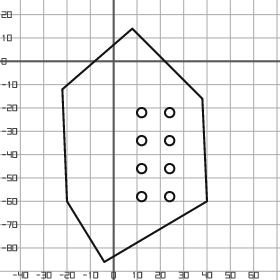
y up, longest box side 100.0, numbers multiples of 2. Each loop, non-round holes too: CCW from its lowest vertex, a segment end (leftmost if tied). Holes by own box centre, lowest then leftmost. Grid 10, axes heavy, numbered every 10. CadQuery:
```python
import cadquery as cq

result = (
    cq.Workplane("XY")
    .moveTo(-4.0, -86.0)
    .lineTo(40.0, -60.0)
    .lineTo(38.0, -16.0)
    .lineTo(8.0, 14.0)
    .lineTo(-22.0, -12.0)
    .lineTo(-20.0, -60.0)
    .close()
    .moveTo(12.0, -58.0)
    .circle(2.0)
    .moveTo(24.0, -58.0)
    .circle(2.0)
    .moveTo(12.0, -46.0)
    .circle(2.0)
    .moveTo(24.0, -46.0)
    .circle(2.0)
    .moveTo(12.0, -34.0)
    .circle(2.0)
    .moveTo(24.0, -34.0)
    .circle(2.0)
    .moveTo(12.0, -22.0)
    .circle(2.0)
    .moveTo(24.0, -22.0)
    .circle(2.0)
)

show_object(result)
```